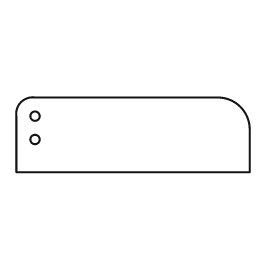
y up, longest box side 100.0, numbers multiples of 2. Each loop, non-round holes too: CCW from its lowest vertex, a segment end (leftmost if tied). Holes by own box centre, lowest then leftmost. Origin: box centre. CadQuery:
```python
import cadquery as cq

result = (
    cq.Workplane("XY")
    .moveTo(-50.0, -16.0)
    .lineTo(50.0, -16.0)
    .lineTo(50.0, 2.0)
    .threePointArc((46.0, 12.0), (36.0, 16.0))
    .lineTo(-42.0, 16.0)
    .threePointArc((-48.0, 14.0), (-50.0, 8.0))
    .close()
    .moveTo(-42.0, -2.0)
    .circle(2.0)
    .moveTo(-42.0, 8.0)
    .circle(2.0)
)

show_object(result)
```